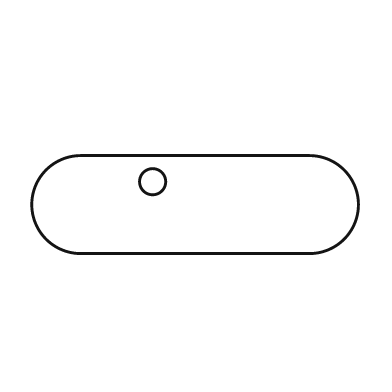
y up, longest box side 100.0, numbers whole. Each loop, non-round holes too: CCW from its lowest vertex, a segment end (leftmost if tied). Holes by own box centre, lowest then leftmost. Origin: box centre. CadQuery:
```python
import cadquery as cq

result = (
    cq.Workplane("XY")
    .moveTo(-35.0, -15.0)
    .lineTo(35.0, -15.0)
    .threePointArc((50.0, 0.0), (35.0, 15.0))
    .lineTo(-35.0, 15.0)
    .threePointArc((-50.0, 0.0), (-35.0, -15.0))
    .close()
    .moveTo(-13.0, 7.0)
    .circle(4.0)
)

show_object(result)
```